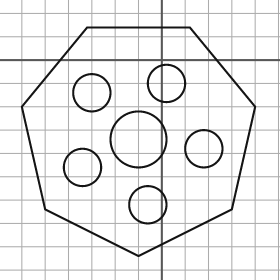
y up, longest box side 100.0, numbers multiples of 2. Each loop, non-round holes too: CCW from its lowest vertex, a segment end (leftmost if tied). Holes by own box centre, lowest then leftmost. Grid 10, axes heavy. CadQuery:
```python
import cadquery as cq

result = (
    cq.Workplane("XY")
    .moveTo(-10.0, -84.0)
    .lineTo(30.0, -64.0)
    .lineTo(40.0, -20.0)
    .lineTo(12.0, 14.0)
    .lineTo(-32.0, 14.0)
    .lineTo(-60.0, -20.0)
    .lineTo(-50.0, -64.0)
    .close()
    .moveTo(-6.0, -62.0)
    .circle(8.0)
    .moveTo(-34.0, -46.0)
    .circle(8.0)
    .moveTo(18.0, -38.0)
    .circle(8.0)
    .moveTo(-10.0, -34.0)
    .circle(12.0)
    .moveTo(-30.0, -14.0)
    .circle(8.0)
    .moveTo(2.0, -10.0)
    .circle(8.0)
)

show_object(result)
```